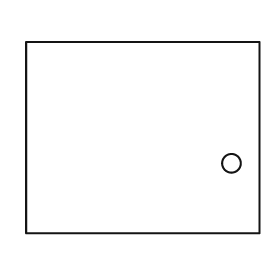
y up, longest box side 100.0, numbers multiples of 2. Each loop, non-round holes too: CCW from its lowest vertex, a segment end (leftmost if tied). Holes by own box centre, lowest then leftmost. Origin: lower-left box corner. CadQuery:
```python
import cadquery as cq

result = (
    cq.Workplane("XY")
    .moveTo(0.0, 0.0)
    .lineTo(100.0, 0.0)
    .lineTo(100.0, 82.0)
    .lineTo(0.0, 82.0)
    .close()
    .moveTo(88.0, 30.0)
    .circle(4.0)
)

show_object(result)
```